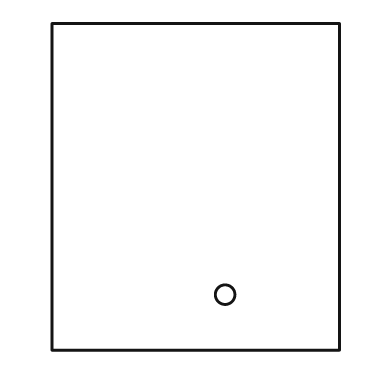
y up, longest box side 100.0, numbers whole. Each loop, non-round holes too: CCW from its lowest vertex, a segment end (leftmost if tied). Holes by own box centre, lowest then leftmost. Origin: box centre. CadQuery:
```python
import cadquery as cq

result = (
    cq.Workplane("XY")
    .moveTo(-44.0, -50.0)
    .lineTo(44.0, -50.0)
    .lineTo(44.0, 50.0)
    .lineTo(-44.0, 50.0)
    .close()
    .moveTo(9.0, -33.0)
    .circle(3.0)
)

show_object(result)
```